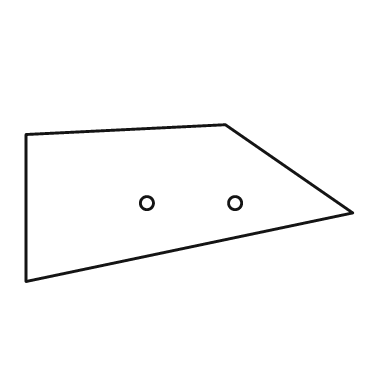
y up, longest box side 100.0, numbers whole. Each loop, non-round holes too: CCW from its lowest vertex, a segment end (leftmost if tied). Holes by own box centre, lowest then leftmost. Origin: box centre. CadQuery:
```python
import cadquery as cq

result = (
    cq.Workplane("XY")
    .moveTo(-50.0, -24.0)
    .lineTo(50.0, -3.0)
    .lineTo(11.0, 24.0)
    .lineTo(-50.0, 21.0)
    .close()
    .moveTo(-13.0, 0.0)
    .circle(2.0)
    .moveTo(14.0, 0.0)
    .circle(2.0)
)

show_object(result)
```